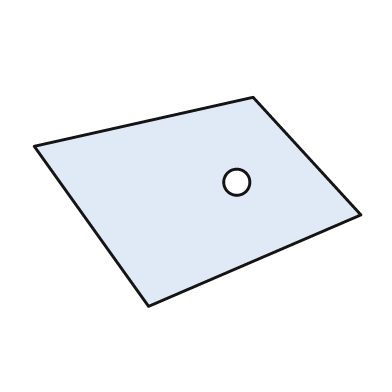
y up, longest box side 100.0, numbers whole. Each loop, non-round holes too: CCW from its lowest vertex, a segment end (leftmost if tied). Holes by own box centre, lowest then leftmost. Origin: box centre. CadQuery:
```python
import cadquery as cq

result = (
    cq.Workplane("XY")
    .moveTo(-15.0, -32.0)
    .lineTo(50.0, -4.0)
    .lineTo(17.0, 32.0)
    .lineTo(-50.0, 17.0)
    .close()
    .moveTo(12.0, 6.0)
    .circle(4.0)
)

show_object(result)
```